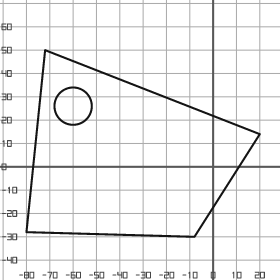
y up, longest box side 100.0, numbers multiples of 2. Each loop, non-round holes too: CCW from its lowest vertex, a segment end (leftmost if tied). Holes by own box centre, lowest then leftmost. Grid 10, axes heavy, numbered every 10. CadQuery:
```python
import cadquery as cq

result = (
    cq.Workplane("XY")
    .moveTo(-8.0, -30.0)
    .lineTo(20.0, 14.0)
    .lineTo(-72.0, 50.0)
    .lineTo(-80.0, -28.0)
    .close()
    .moveTo(-60.0, 26.0)
    .circle(8.0)
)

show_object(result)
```